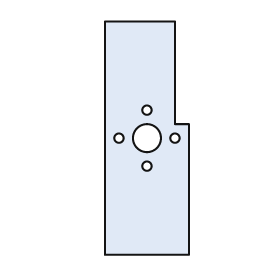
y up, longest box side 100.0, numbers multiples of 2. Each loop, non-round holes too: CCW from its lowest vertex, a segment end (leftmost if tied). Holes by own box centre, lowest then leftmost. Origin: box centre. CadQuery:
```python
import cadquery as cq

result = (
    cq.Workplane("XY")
    .moveTo(-18.0, -50.0)
    .lineTo(18.0, -50.0)
    .lineTo(18.0, 6.0)
    .lineTo(12.0, 6.0)
    .lineTo(12.0, 50.0)
    .lineTo(-18.0, 50.0)
    .close()
    .moveTo(0.0, -12.0)
    .circle(2.0)
    .moveTo(-12.0, 0.0)
    .circle(2.0)
    .moveTo(0.0, 0.0)
    .circle(6.0)
    .moveTo(12.0, 0.0)
    .circle(2.0)
    .moveTo(0.0, 12.0)
    .circle(2.0)
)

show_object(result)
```